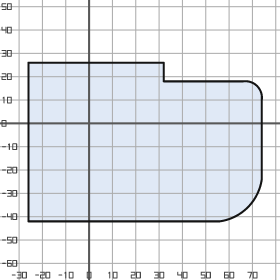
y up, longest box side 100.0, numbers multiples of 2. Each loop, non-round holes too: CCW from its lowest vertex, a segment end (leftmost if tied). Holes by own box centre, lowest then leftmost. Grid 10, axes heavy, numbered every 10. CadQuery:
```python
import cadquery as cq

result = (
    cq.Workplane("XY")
    .moveTo(-26.0, -42.0)
    .lineTo(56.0, -42.0)
    .threePointArc((68.0, -36.0), (74.0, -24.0))
    .lineTo(74.0, 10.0)
    .threePointArc((72.0, 16.0), (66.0, 18.0))
    .lineTo(32.0, 18.0)
    .lineTo(32.0, 26.0)
    .lineTo(-26.0, 26.0)
    .close()
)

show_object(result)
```